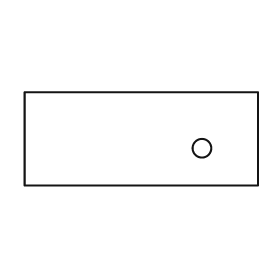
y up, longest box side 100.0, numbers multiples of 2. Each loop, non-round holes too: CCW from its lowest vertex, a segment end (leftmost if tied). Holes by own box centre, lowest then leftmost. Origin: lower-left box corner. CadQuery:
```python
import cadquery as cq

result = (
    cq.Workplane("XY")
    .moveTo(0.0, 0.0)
    .lineTo(100.0, 0.0)
    .lineTo(100.0, 40.0)
    .lineTo(0.0, 40.0)
    .close()
    .moveTo(76.0, 16.0)
    .circle(4.0)
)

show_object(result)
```